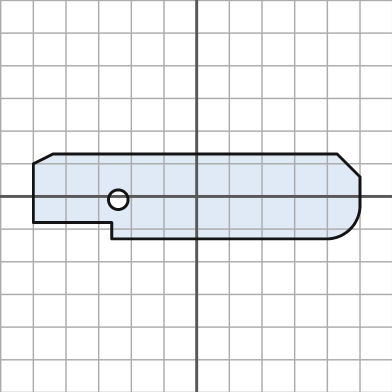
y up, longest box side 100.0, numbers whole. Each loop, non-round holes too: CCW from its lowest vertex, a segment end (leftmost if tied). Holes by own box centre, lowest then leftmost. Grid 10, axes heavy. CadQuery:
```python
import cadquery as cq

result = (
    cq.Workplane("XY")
    .moveTo(-26.0, -13.0)
    .lineTo(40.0, -13.0)
    .threePointArc((47.0, -10.0), (50.0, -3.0))
    .lineTo(50.0, 6.0)
    .lineTo(43.0, 13.0)
    .lineTo(-44.0, 13.0)
    .lineTo(-50.0, 10.0)
    .lineTo(-50.0, -8.0)
    .lineTo(-26.0, -8.0)
    .close()
    .moveTo(-24.0, -1.0)
    .circle(3.0)
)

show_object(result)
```